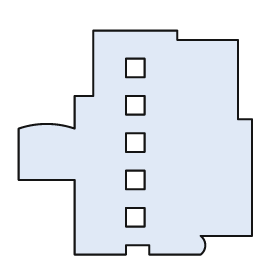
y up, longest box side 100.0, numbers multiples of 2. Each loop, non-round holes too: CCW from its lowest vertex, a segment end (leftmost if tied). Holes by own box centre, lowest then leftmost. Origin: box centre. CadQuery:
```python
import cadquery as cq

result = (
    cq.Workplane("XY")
    .moveTo(-26.0, -48.0)
    .lineTo(-4.0, -48.0)
    .lineTo(-4.0, -44.0)
    .lineTo(6.0, -44.0)
    .lineTo(6.0, -48.0)
    .lineTo(28.0, -48.0)
    .threePointArc((30.0, -44.0), (28.0, -40.0))
    .lineTo(50.0, -40.0)
    .lineTo(50.0, 10.0)
    .lineTo(44.0, 10.0)
    .lineTo(44.0, 44.0)
    .lineTo(18.0, 44.0)
    .lineTo(18.0, 48.0)
    .lineTo(-18.0, 48.0)
    .lineTo(-18.0, 20.0)
    .lineTo(-26.0, 20.0)
    .lineTo(-26.0, 6.0)
    .threePointArc((-38.0, 8.0), (-50.0, 6.0))
    .lineTo(-50.0, -16.0)
    .lineTo(-26.0, -16.0)
    .close()
    .moveTo(-4.0, -36.0)
    .lineTo(4.0, -36.0)
    .lineTo(4.0, -28.0)
    .lineTo(-4.0, -28.0)
    .close()
    .moveTo(-4.0, -20.0)
    .lineTo(4.0, -20.0)
    .lineTo(4.0, -12.0)
    .lineTo(-4.0, -12.0)
    .close()
    .moveTo(-4.0, -4.0)
    .lineTo(4.0, -4.0)
    .lineTo(4.0, 4.0)
    .lineTo(-4.0, 4.0)
    .close()
    .moveTo(-4.0, 12.0)
    .lineTo(4.0, 12.0)
    .lineTo(4.0, 20.0)
    .lineTo(-4.0, 20.0)
    .close()
    .moveTo(-4.0, 28.0)
    .lineTo(4.0, 28.0)
    .lineTo(4.0, 36.0)
    .lineTo(-4.0, 36.0)
    .close()
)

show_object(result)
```